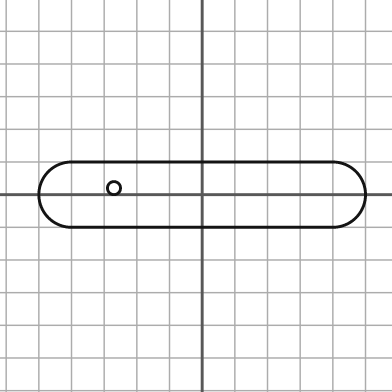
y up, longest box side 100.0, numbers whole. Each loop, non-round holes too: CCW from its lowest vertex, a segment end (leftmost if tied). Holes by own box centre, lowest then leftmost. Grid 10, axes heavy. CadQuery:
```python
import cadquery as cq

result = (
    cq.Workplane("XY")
    .moveTo(-40.0, -10.0)
    .lineTo(40.0, -10.0)
    .threePointArc((50.0, 0.0), (40.0, 10.0))
    .lineTo(-40.0, 10.0)
    .threePointArc((-50.0, 0.0), (-40.0, -10.0))
    .close()
    .moveTo(-27.0, 2.0)
    .circle(2.0)
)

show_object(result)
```